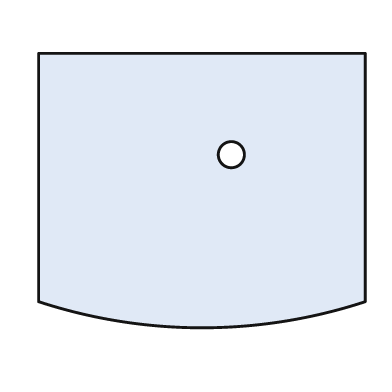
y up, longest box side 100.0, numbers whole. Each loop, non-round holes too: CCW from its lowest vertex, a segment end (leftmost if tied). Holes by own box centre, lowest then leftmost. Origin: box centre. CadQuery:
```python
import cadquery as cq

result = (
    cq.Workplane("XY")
    .moveTo(-50.0, -34.0)
    .threePointArc((0.0, -42.0), (50.0, -34.0))
    .lineTo(50.0, 42.0)
    .lineTo(-50.0, 42.0)
    .close()
    .moveTo(9.0, 11.0)
    .circle(4.0)
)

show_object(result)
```